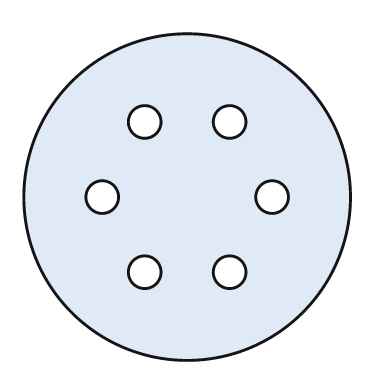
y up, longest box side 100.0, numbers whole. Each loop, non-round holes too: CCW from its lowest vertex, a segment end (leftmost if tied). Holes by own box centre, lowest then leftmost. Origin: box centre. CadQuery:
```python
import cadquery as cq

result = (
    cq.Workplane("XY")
    .moveTo(0.0, 0.0)
    .circle(50.0)
    .moveTo(-13.0, -23.0)
    .circle(5.0)
    .moveTo(13.0, -23.0)
    .circle(5.0)
    .moveTo(-26.0, 0.0)
    .circle(5.0)
    .moveTo(26.0, 0.0)
    .circle(5.0)
    .moveTo(-13.0, 23.0)
    .circle(5.0)
    .moveTo(13.0, 23.0)
    .circle(5.0)
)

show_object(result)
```